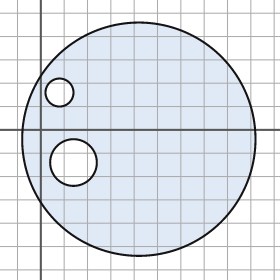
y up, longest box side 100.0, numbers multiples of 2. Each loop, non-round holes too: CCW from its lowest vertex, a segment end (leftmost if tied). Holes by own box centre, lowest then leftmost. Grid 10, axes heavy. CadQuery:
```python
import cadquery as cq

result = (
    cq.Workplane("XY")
    .moveTo(42.0, -4.0)
    .circle(50.0)
    .moveTo(14.0, -14.0)
    .circle(10.0)
    .moveTo(8.0, 16.0)
    .circle(6.0)
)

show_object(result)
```